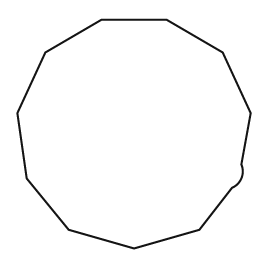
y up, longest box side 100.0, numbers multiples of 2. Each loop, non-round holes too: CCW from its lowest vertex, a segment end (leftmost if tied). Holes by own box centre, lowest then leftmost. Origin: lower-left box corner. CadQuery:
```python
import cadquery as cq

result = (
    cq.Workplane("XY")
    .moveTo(50.0, 0.0)
    .lineTo(78.0, 8.0)
    .lineTo(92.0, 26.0)
    .threePointArc((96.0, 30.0), (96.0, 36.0))
    .lineTo(100.0, 58.0)
    .lineTo(88.0, 84.0)
    .lineTo(64.0, 98.0)
    .lineTo(36.0, 98.0)
    .lineTo(12.0, 84.0)
    .lineTo(0.0, 58.0)
    .lineTo(4.0, 30.0)
    .lineTo(22.0, 8.0)
    .close()
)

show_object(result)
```